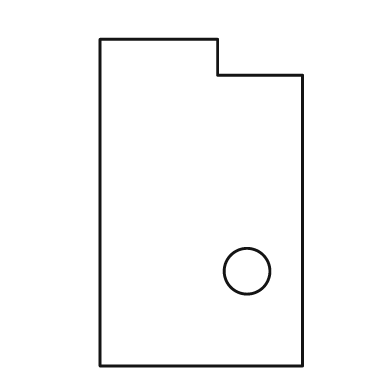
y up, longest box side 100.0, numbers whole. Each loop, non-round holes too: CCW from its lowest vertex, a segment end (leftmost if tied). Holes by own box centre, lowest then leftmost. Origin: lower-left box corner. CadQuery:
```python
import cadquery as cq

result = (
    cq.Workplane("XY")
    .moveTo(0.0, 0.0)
    .lineTo(62.0, 0.0)
    .lineTo(62.0, 89.0)
    .lineTo(36.0, 89.0)
    .lineTo(36.0, 100.0)
    .lineTo(0.0, 100.0)
    .close()
    .moveTo(45.0, 29.0)
    .circle(7.0)
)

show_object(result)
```